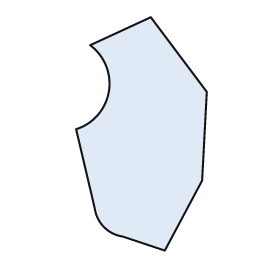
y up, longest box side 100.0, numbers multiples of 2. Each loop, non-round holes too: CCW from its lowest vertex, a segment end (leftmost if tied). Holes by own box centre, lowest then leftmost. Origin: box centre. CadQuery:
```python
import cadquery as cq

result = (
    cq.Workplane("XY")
    .moveTo(10.0, -50.0)
    .lineTo(26.0, -20.0)
    .lineTo(28.0, 18.0)
    .lineTo(4.0, 50.0)
    .lineTo(-22.0, 38.0)
    .threePointArc((-14.0, 18.0), (-28.0, 2.0))
    .lineTo(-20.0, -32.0)
    .threePointArc((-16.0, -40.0), (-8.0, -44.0))
    .close()
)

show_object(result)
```